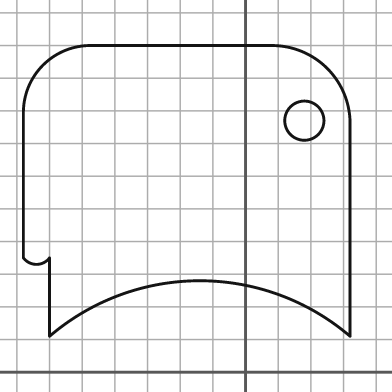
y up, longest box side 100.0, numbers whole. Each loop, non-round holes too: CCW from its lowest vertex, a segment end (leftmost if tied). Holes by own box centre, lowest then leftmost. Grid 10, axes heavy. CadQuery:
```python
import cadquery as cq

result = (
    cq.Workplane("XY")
    .moveTo(-60.0, 11.0)
    .threePointArc((-14.0, 28.0), (32.0, 11.0))
    .lineTo(32.0, 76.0)
    .threePointArc((25.0, 93.0), (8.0, 100.0))
    .lineTo(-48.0, 100.0)
    .threePointArc((-62.0, 94.0), (-68.0, 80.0))
    .lineTo(-68.0, 35.0)
    .threePointArc((-64.0, 33.0), (-60.0, 35.0))
    .close()
    .moveTo(18.0, 77.0)
    .circle(6.0)
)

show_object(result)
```